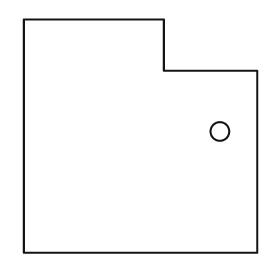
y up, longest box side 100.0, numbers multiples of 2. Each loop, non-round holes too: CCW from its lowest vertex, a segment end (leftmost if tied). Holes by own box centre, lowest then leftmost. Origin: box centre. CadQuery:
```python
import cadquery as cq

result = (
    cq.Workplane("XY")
    .moveTo(-50.0, -50.0)
    .lineTo(50.0, -50.0)
    .lineTo(50.0, 28.0)
    .lineTo(10.0, 28.0)
    .lineTo(10.0, 50.0)
    .lineTo(-50.0, 50.0)
    .close()
    .moveTo(34.0, 2.0)
    .circle(4.0)
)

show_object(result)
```